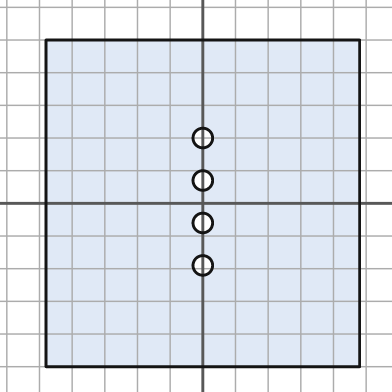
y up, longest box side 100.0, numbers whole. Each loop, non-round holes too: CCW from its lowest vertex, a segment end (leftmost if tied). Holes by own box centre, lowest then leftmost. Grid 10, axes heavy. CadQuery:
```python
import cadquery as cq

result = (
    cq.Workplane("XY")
    .moveTo(-48.0, -50.0)
    .lineTo(48.0, -50.0)
    .lineTo(48.0, 50.0)
    .lineTo(-48.0, 50.0)
    .close()
    .moveTo(0.0, -19.0)
    .circle(3.0)
    .moveTo(0.0, -6.0)
    .circle(3.0)
    .moveTo(0.0, 7.0)
    .circle(3.0)
    .moveTo(0.0, 20.0)
    .circle(3.0)
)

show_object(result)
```